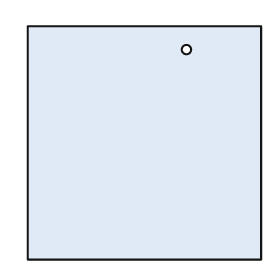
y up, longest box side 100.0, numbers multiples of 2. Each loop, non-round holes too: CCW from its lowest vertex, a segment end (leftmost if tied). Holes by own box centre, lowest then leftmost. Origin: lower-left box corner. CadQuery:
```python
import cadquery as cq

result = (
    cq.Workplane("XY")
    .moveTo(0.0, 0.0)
    .lineTo(100.0, 0.0)
    .lineTo(100.0, 100.0)
    .lineTo(0.0, 100.0)
    .close()
    .moveTo(68.0, 90.0)
    .circle(2.0)
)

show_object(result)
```